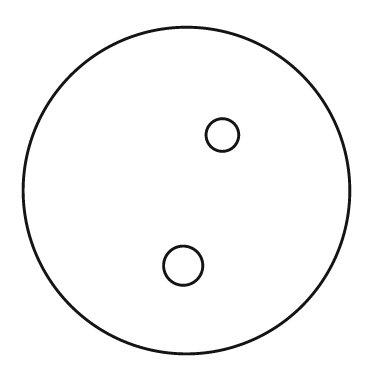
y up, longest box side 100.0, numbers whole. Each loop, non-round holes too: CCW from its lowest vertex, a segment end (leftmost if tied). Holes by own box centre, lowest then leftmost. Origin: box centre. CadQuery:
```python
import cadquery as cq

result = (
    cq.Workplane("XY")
    .moveTo(0.0, 0.0)
    .circle(50.0)
    .moveTo(-1.0, -23.0)
    .circle(6.0)
    .moveTo(11.0, 17.0)
    .circle(5.0)
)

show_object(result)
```